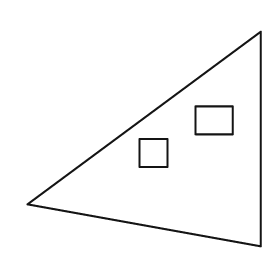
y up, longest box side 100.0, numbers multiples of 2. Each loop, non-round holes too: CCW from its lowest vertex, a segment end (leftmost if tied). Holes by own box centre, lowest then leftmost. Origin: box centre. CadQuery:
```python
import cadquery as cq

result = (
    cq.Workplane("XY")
    .moveTo(50.0, -46.0)
    .lineTo(50.0, 46.0)
    .lineTo(-50.0, -28.0)
    .close()
    .moveTo(-2.0, -12.0)
    .lineTo(10.0, -12.0)
    .lineTo(10.0, 0.0)
    .lineTo(-2.0, 0.0)
    .close()
    .moveTo(22.0, 2.0)
    .lineTo(38.0, 2.0)
    .lineTo(38.0, 14.0)
    .lineTo(22.0, 14.0)
    .close()
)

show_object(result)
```